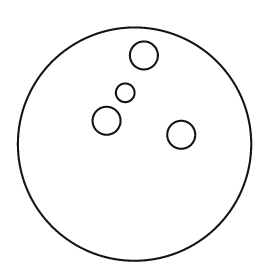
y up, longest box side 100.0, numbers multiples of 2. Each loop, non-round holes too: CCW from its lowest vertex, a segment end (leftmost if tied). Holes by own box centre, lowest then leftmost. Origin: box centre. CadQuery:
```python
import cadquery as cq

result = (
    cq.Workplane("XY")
    .moveTo(0.0, 0.0)
    .circle(50.0)
    .moveTo(20.0, 4.0)
    .circle(6.0)
    .moveTo(-12.0, 10.0)
    .circle(6.0)
    .moveTo(-4.0, 22.0)
    .circle(4.0)
    .moveTo(4.0, 38.0)
    .circle(6.0)
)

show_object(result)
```